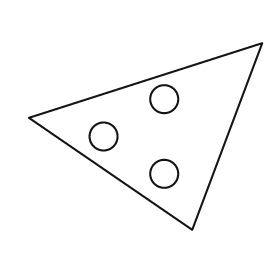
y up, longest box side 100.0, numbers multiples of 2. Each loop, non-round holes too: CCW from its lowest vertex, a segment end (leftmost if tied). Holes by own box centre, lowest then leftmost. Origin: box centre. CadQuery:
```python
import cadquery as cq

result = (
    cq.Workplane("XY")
    .moveTo(20.0, -40.0)
    .lineTo(50.0, 40.0)
    .lineTo(-50.0, 8.0)
    .close()
    .moveTo(8.0, -16.0)
    .circle(6.0)
    .moveTo(-18.0, 0.0)
    .circle(6.0)
    .moveTo(8.0, 16.0)
    .circle(6.0)
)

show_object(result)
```